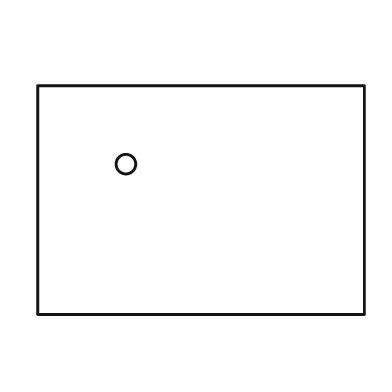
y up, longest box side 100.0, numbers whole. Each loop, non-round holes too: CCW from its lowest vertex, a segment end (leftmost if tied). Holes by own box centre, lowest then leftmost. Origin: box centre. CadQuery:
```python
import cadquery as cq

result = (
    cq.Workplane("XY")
    .moveTo(-50.0, -35.0)
    .lineTo(50.0, -35.0)
    .lineTo(50.0, 35.0)
    .lineTo(-50.0, 35.0)
    .close()
    .moveTo(-23.0, 11.0)
    .circle(3.0)
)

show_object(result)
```